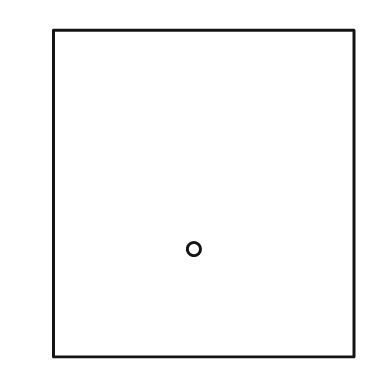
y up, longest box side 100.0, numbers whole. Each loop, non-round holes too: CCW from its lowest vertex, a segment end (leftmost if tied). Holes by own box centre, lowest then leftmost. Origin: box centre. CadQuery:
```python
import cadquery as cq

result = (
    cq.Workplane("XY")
    .moveTo(-46.0, -50.0)
    .lineTo(46.0, -50.0)
    .lineTo(46.0, 50.0)
    .lineTo(-46.0, 50.0)
    .close()
    .moveTo(-3.0, -17.0)
    .circle(2.0)
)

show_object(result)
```